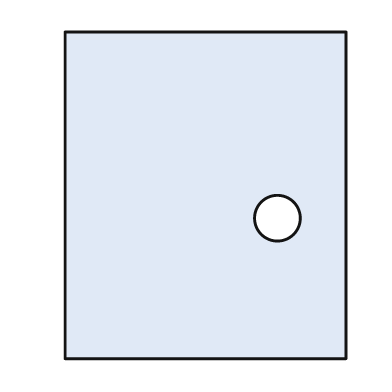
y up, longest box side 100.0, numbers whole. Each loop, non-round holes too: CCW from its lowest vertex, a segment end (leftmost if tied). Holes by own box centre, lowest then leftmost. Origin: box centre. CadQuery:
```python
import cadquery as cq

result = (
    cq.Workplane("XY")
    .moveTo(-43.0, -50.0)
    .lineTo(43.0, -50.0)
    .lineTo(43.0, 50.0)
    .lineTo(-43.0, 50.0)
    .close()
    .moveTo(22.0, -7.0)
    .circle(7.0)
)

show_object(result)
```